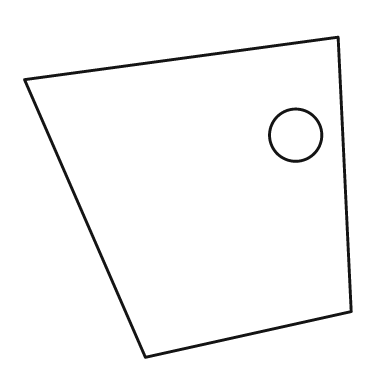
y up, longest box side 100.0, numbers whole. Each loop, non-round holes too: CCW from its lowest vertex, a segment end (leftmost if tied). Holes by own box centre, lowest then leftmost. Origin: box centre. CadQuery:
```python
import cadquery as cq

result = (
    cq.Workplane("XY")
    .moveTo(-13.0, -49.0)
    .lineTo(50.0, -35.0)
    .lineTo(46.0, 49.0)
    .lineTo(-50.0, 36.0)
    .close()
    .moveTo(33.0, 19.0)
    .circle(8.0)
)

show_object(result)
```